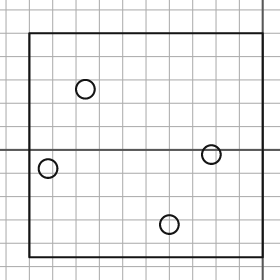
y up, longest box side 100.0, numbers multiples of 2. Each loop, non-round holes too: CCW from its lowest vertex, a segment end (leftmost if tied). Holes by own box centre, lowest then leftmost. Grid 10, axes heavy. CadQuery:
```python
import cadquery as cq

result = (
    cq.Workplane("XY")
    .moveTo(-100.0, -46.0)
    .lineTo(0.0, -46.0)
    .lineTo(0.0, 50.0)
    .lineTo(-100.0, 50.0)
    .close()
    .moveTo(-40.0, -32.0)
    .circle(4.0)
    .moveTo(-92.0, -8.0)
    .circle(4.0)
    .moveTo(-22.0, -2.0)
    .circle(4.0)
    .moveTo(-76.0, 26.0)
    .circle(4.0)
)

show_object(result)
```